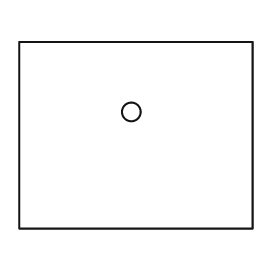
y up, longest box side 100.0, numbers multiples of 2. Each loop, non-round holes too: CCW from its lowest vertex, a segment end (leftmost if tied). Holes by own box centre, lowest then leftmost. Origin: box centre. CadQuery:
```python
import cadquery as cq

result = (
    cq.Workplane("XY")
    .moveTo(-50.0, -40.0)
    .lineTo(50.0, -40.0)
    .lineTo(50.0, 40.0)
    .lineTo(-50.0, 40.0)
    .close()
    .moveTo(-2.0, 10.0)
    .circle(4.0)
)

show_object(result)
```